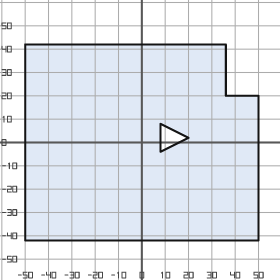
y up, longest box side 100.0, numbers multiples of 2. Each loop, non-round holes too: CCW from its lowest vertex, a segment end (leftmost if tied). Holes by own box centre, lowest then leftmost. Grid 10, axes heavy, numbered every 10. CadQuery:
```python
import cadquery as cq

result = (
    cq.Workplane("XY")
    .moveTo(-50.0, -42.0)
    .lineTo(50.0, -42.0)
    .lineTo(50.0, 20.0)
    .lineTo(36.0, 20.0)
    .lineTo(36.0, 42.0)
    .lineTo(-50.0, 42.0)
    .close()
    .moveTo(8.0, -4.0)
    .lineTo(20.0, 2.0)
    .lineTo(8.0, 8.0)
    .close()
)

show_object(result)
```